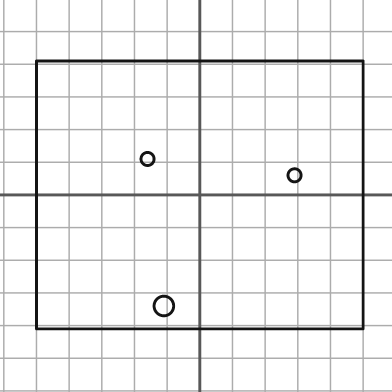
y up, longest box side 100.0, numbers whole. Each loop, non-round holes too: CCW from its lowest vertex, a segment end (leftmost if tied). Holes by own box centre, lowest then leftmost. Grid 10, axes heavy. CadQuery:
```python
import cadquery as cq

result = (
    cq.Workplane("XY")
    .moveTo(-50.0, -41.0)
    .lineTo(50.0, -41.0)
    .lineTo(50.0, 41.0)
    .lineTo(-50.0, 41.0)
    .close()
    .moveTo(-11.0, -34.0)
    .circle(3.0)
    .moveTo(29.0, 6.0)
    .circle(2.0)
    .moveTo(-16.0, 11.0)
    .circle(2.0)
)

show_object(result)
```